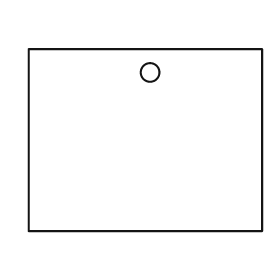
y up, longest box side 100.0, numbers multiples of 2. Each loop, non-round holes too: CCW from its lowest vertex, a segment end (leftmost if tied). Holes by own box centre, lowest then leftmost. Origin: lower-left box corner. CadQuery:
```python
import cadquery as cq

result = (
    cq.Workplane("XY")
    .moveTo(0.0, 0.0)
    .lineTo(100.0, 0.0)
    .lineTo(100.0, 78.0)
    .lineTo(0.0, 78.0)
    .close()
    .moveTo(52.0, 68.0)
    .circle(4.0)
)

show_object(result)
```